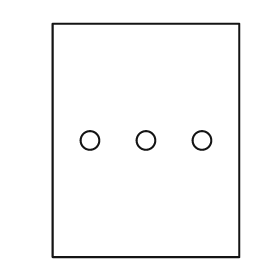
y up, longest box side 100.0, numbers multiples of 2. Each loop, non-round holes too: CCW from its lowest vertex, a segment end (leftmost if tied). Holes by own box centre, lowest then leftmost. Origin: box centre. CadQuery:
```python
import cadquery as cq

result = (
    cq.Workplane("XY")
    .moveTo(-40.0, -50.0)
    .lineTo(40.0, -50.0)
    .lineTo(40.0, 50.0)
    .lineTo(-40.0, 50.0)
    .close()
    .moveTo(-24.0, 0.0)
    .circle(4.0)
    .moveTo(0.0, 0.0)
    .circle(4.0)
    .moveTo(24.0, 0.0)
    .circle(4.0)
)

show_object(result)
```